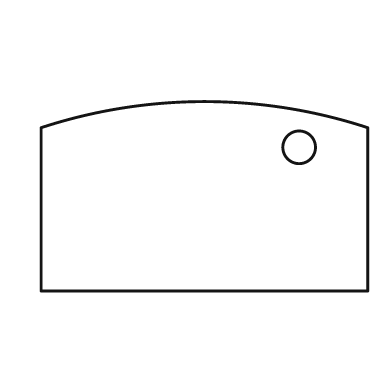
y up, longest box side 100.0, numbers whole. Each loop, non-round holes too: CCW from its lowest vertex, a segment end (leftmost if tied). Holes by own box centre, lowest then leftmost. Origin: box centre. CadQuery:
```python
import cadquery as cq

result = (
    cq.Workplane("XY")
    .moveTo(-50.0, -29.0)
    .lineTo(50.0, -29.0)
    .lineTo(50.0, 21.0)
    .threePointArc((0.0, 29.0), (-50.0, 21.0))
    .close()
    .moveTo(29.0, 15.0)
    .circle(5.0)
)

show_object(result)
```